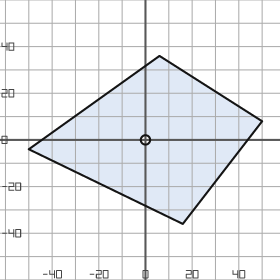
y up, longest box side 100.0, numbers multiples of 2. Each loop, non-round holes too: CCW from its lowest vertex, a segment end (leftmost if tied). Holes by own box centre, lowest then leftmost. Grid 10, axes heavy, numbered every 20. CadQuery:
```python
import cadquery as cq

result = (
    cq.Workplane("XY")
    .moveTo(16.0, -36.0)
    .lineTo(50.0, 8.0)
    .lineTo(6.0, 36.0)
    .lineTo(-50.0, -4.0)
    .close()
    .moveTo(0.0, 0.0)
    .circle(2.0)
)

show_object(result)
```